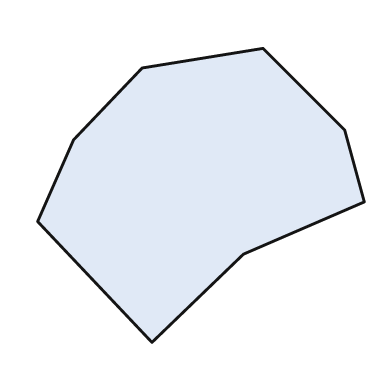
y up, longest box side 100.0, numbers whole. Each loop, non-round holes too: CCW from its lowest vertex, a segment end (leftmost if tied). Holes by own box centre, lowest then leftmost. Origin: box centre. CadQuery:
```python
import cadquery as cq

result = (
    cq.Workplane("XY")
    .moveTo(-15.0, -45.0)
    .lineTo(13.0, -18.0)
    .lineTo(50.0, -2.0)
    .lineTo(44.0, 20.0)
    .lineTo(19.0, 45.0)
    .lineTo(-18.0, 39.0)
    .lineTo(-39.0, 17.0)
    .lineTo(-50.0, -8.0)
    .close()
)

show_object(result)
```